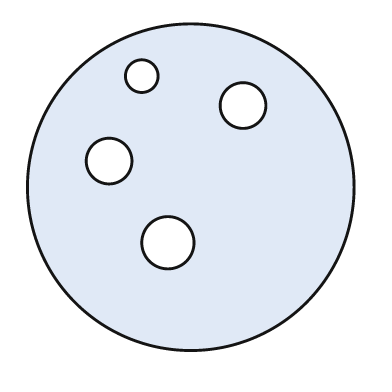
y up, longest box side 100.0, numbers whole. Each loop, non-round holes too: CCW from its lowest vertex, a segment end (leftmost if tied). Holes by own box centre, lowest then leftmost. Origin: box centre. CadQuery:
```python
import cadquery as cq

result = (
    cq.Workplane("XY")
    .moveTo(0.0, 0.0)
    .circle(50.0)
    .moveTo(-7.0, -17.0)
    .circle(8.0)
    .moveTo(-25.0, 8.0)
    .circle(7.0)
    .moveTo(16.0, 25.0)
    .circle(7.0)
    .moveTo(-15.0, 34.0)
    .circle(5.0)
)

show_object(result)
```